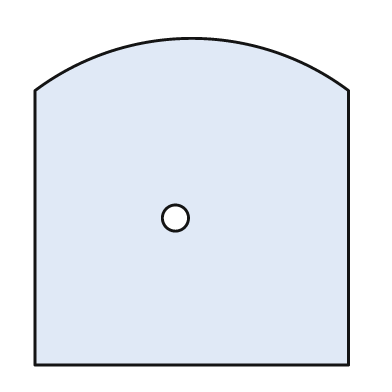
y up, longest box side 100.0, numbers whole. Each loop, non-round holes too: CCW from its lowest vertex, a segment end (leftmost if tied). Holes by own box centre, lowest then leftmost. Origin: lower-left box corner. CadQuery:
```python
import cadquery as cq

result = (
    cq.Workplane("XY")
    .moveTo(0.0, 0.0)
    .lineTo(96.0, 0.0)
    .lineTo(96.0, 84.0)
    .threePointArc((48.0, 100.0), (0.0, 84.0))
    .close()
    .moveTo(43.0, 45.0)
    .circle(4.0)
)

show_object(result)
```